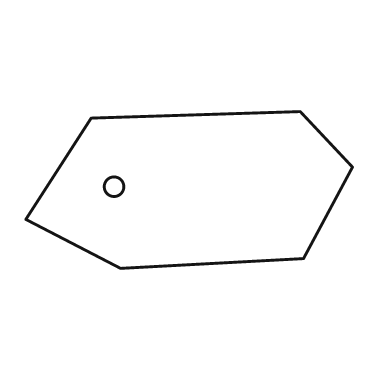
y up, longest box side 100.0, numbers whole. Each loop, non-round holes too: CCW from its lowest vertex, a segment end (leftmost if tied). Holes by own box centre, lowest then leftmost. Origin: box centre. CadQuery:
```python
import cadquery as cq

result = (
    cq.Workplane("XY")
    .moveTo(-21.0, -24.0)
    .lineTo(35.0, -21.0)
    .lineTo(50.0, 7.0)
    .lineTo(34.0, 24.0)
    .lineTo(-30.0, 22.0)
    .lineTo(-50.0, -9.0)
    .close()
    .moveTo(-23.0, 1.0)
    .circle(3.0)
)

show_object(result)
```